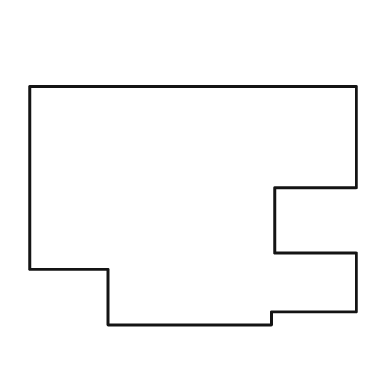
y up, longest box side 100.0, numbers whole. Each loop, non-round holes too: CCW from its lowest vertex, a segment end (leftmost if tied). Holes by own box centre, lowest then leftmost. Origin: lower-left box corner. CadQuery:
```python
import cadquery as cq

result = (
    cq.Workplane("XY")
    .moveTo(24.0, 0.0)
    .lineTo(74.0, 0.0)
    .lineTo(74.0, 4.0)
    .lineTo(100.0, 4.0)
    .lineTo(100.0, 22.0)
    .lineTo(75.0, 22.0)
    .lineTo(75.0, 42.0)
    .lineTo(100.0, 42.0)
    .lineTo(100.0, 73.0)
    .lineTo(0.0, 73.0)
    .lineTo(0.0, 17.0)
    .lineTo(24.0, 17.0)
    .close()
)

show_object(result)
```